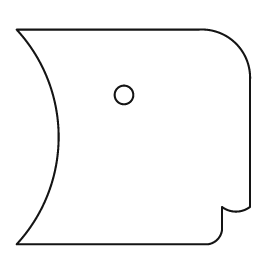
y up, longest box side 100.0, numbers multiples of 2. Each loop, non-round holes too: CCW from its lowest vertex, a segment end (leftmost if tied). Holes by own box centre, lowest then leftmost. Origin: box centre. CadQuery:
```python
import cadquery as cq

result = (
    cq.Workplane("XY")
    .moveTo(-50.0, -46.0)
    .lineTo(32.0, -46.0)
    .threePointArc((36.0, -44.0), (38.0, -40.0))
    .lineTo(38.0, -30.0)
    .threePointArc((44.0, -32.0), (50.0, -30.0))
    .lineTo(50.0, 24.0)
    .threePointArc((44.0, 40.0), (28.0, 46.0))
    .lineTo(-50.0, 46.0)
    .threePointArc((-32.0, 0.0), (-50.0, -46.0))
    .close()
    .moveTo(-4.0, 18.0)
    .circle(4.0)
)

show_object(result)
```